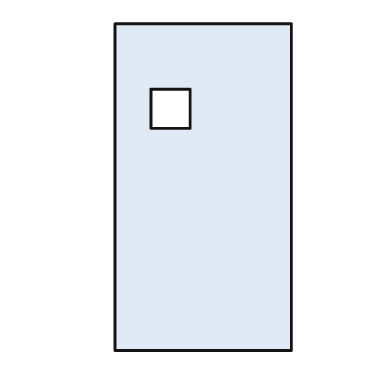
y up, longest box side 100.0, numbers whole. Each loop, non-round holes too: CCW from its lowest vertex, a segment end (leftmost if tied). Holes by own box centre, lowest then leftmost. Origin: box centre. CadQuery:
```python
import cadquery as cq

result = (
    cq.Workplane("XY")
    .moveTo(-27.0, -50.0)
    .lineTo(27.0, -50.0)
    .lineTo(27.0, 50.0)
    .lineTo(-27.0, 50.0)
    .close()
    .moveTo(-16.0, 18.0)
    .lineTo(-4.0, 18.0)
    .lineTo(-4.0, 30.0)
    .lineTo(-16.0, 30.0)
    .close()
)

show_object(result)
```